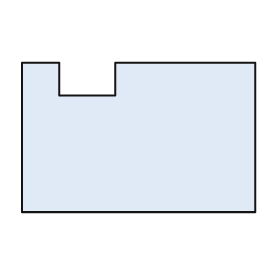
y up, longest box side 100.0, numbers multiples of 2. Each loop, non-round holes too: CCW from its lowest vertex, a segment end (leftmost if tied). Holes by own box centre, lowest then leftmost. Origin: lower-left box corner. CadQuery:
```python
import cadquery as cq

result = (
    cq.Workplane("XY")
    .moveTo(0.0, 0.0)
    .lineTo(100.0, 0.0)
    .lineTo(100.0, 64.0)
    .lineTo(40.0, 64.0)
    .lineTo(40.0, 50.0)
    .lineTo(16.0, 50.0)
    .lineTo(16.0, 64.0)
    .lineTo(0.0, 64.0)
    .close()
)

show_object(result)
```